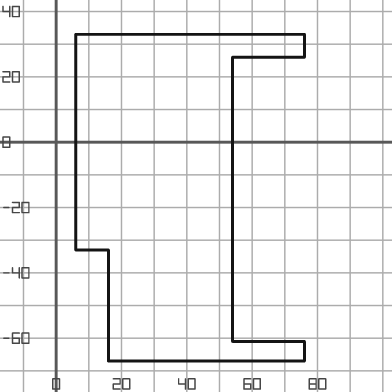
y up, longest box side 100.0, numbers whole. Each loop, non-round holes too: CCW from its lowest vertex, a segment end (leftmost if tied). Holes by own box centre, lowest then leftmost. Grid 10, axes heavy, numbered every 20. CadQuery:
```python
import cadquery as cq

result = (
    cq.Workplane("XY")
    .moveTo(16.0, -67.0)
    .lineTo(76.0, -67.0)
    .lineTo(76.0, -61.0)
    .lineTo(54.0, -61.0)
    .lineTo(54.0, 26.0)
    .lineTo(76.0, 26.0)
    .lineTo(76.0, 33.0)
    .lineTo(6.0, 33.0)
    .lineTo(6.0, -33.0)
    .lineTo(16.0, -33.0)
    .close()
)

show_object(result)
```